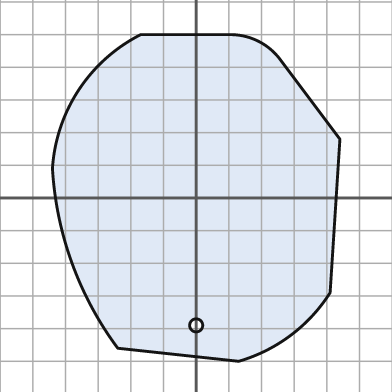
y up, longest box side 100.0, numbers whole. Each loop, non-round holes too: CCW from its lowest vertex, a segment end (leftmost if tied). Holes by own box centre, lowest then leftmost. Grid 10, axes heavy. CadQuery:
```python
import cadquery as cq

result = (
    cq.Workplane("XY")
    .moveTo(13.0, -50.0)
    .threePointArc((29.0, -42.0), (41.0, -29.0))
    .lineTo(44.0, 18.0)
    .lineTo(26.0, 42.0)
    .threePointArc((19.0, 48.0), (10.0, 50.0))
    .lineTo(-17.0, 50.0)
    .threePointArc((-36.0, 33.0), (-44.0, 9.0))
    .threePointArc((-38.0, -20.0), (-24.0, -46.0))
    .close()
    .moveTo(0.0, -39.0)
    .circle(2.0)
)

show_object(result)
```